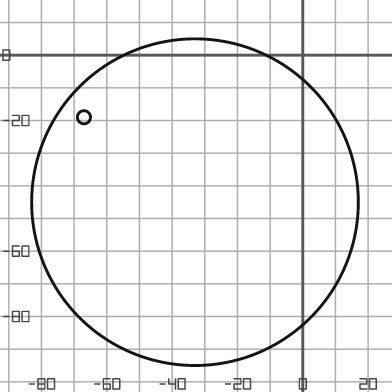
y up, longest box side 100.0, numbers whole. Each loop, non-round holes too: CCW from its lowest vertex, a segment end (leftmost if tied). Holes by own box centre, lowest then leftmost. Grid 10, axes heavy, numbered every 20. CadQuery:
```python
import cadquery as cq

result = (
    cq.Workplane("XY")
    .moveTo(-33.0, -45.0)
    .circle(50.0)
    .moveTo(-67.0, -19.0)
    .circle(2.0)
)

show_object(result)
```